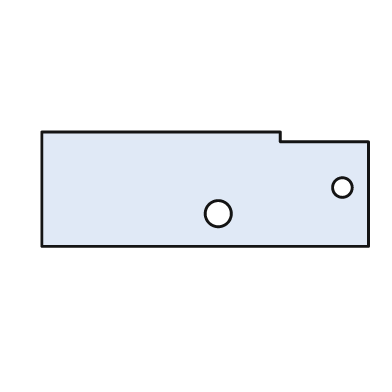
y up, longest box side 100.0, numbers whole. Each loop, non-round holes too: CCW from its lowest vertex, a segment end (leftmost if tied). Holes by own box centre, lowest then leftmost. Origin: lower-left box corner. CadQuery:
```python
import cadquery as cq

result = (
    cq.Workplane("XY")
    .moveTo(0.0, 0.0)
    .lineTo(100.0, 0.0)
    .lineTo(100.0, 32.0)
    .lineTo(73.0, 32.0)
    .lineTo(73.0, 35.0)
    .lineTo(0.0, 35.0)
    .close()
    .moveTo(54.0, 10.0)
    .circle(4.0)
    .moveTo(92.0, 18.0)
    .circle(3.0)
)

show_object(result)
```